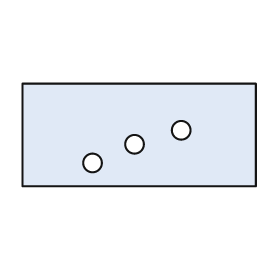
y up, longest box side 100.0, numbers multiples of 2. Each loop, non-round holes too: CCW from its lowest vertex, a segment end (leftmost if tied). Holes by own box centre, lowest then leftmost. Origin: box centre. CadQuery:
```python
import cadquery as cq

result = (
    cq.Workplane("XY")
    .moveTo(-50.0, -22.0)
    .lineTo(50.0, -22.0)
    .lineTo(50.0, 22.0)
    .lineTo(-50.0, 22.0)
    .close()
    .moveTo(-20.0, -12.0)
    .circle(4.0)
    .moveTo(-2.0, -4.0)
    .circle(4.0)
    .moveTo(18.0, 2.0)
    .circle(4.0)
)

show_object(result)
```